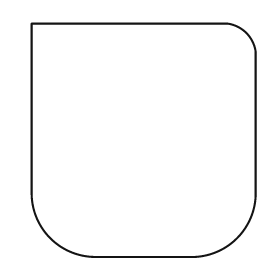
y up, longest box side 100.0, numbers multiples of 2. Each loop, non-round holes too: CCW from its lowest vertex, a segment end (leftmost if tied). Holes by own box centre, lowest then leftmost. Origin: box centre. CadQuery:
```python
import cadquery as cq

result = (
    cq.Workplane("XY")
    .moveTo(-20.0, -50.0)
    .lineTo(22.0, -50.0)
    .threePointArc((40.0, -42.0), (48.0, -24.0))
    .lineTo(48.0, 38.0)
    .threePointArc((44.0, 46.0), (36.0, 50.0))
    .lineTo(-48.0, 50.0)
    .lineTo(-48.0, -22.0)
    .threePointArc((-40.0, -42.0), (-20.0, -50.0))
    .close()
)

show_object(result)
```